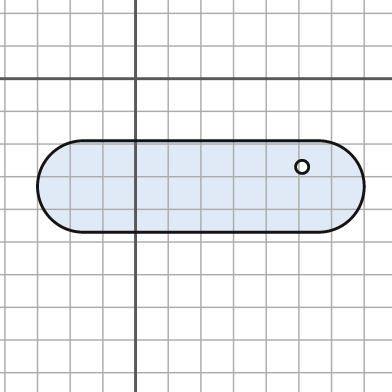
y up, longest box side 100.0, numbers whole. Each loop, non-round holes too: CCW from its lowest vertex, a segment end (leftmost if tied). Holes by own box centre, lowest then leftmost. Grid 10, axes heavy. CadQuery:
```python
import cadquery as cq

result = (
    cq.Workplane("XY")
    .moveTo(-16.0, -47.0)
    .lineTo(56.0, -47.0)
    .threePointArc((70.0, -33.0), (56.0, -19.0))
    .lineTo(-16.0, -19.0)
    .threePointArc((-30.0, -33.0), (-16.0, -47.0))
    .close()
    .moveTo(51.0, -27.0)
    .circle(2.0)
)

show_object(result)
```